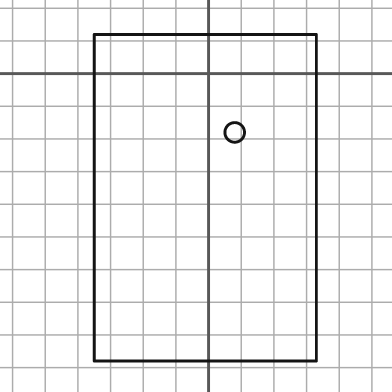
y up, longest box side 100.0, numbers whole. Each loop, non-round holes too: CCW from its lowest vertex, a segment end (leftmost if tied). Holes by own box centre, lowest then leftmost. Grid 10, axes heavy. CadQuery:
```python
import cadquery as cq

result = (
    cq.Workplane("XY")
    .moveTo(-35.0, -88.0)
    .lineTo(33.0, -88.0)
    .lineTo(33.0, 12.0)
    .lineTo(-35.0, 12.0)
    .close()
    .moveTo(8.0, -18.0)
    .circle(3.0)
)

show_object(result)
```